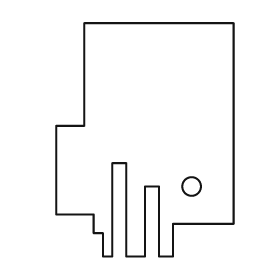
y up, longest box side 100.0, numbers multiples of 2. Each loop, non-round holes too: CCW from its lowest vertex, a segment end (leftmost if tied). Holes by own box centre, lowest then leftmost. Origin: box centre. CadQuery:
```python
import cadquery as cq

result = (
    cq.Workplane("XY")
    .moveTo(-18.0, -50.0)
    .lineTo(-14.0, -50.0)
    .lineTo(-14.0, -10.0)
    .lineTo(-8.0, -10.0)
    .lineTo(-8.0, -50.0)
    .lineTo(0.0, -50.0)
    .lineTo(0.0, -20.0)
    .lineTo(6.0, -20.0)
    .lineTo(6.0, -50.0)
    .lineTo(12.0, -50.0)
    .lineTo(12.0, -36.0)
    .lineTo(38.0, -36.0)
    .lineTo(38.0, 50.0)
    .lineTo(-26.0, 50.0)
    .lineTo(-26.0, 6.0)
    .lineTo(-38.0, 6.0)
    .lineTo(-38.0, -32.0)
    .lineTo(-22.0, -32.0)
    .lineTo(-22.0, -40.0)
    .lineTo(-18.0, -40.0)
    .close()
    .moveTo(20.0, -20.0)
    .circle(4.0)
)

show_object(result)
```